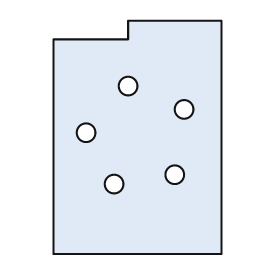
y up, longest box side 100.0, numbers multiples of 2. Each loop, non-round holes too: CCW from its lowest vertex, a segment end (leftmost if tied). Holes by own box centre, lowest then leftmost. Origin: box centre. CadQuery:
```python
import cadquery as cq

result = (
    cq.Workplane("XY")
    .moveTo(-36.0, -50.0)
    .lineTo(36.0, -50.0)
    .lineTo(36.0, 50.0)
    .lineTo(-4.0, 50.0)
    .lineTo(-4.0, 42.0)
    .lineTo(-36.0, 42.0)
    .close()
    .moveTo(-10.0, -20.0)
    .circle(4.0)
    .moveTo(16.0, -16.0)
    .circle(4.0)
    .moveTo(-22.0, 2.0)
    .circle(4.0)
    .moveTo(20.0, 12.0)
    .circle(4.0)
    .moveTo(-4.0, 22.0)
    .circle(4.0)
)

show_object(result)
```